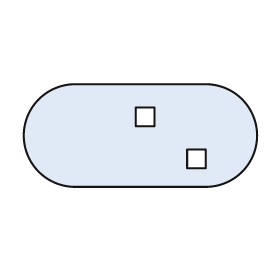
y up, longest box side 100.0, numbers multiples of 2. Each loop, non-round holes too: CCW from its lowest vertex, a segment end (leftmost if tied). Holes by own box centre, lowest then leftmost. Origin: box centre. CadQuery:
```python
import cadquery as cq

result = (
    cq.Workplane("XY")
    .moveTo(-28.0, -22.0)
    .lineTo(28.0, -22.0)
    .threePointArc((50.0, 0.0), (28.0, 22.0))
    .lineTo(-28.0, 22.0)
    .threePointArc((-50.0, 0.0), (-28.0, -22.0))
    .close()
    .moveTo(20.0, -14.0)
    .lineTo(28.0, -14.0)
    .lineTo(28.0, -6.0)
    .lineTo(20.0, -6.0)
    .close()
    .moveTo(-2.0, 4.0)
    .lineTo(6.0, 4.0)
    .lineTo(6.0, 12.0)
    .lineTo(-2.0, 12.0)
    .close()
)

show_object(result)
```